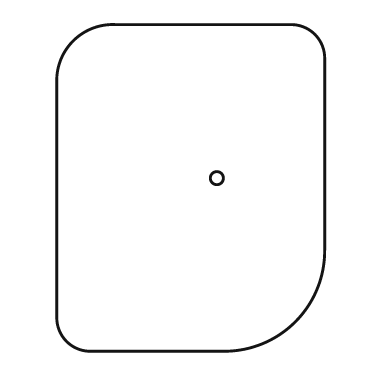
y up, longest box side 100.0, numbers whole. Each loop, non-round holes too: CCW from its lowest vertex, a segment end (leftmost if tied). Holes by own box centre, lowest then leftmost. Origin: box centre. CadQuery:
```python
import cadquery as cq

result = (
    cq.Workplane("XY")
    .moveTo(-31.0, -50.0)
    .lineTo(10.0, -50.0)
    .threePointArc((32.0, -41.0), (41.0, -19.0))
    .lineTo(41.0, 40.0)
    .threePointArc((38.0, 47.0), (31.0, 50.0))
    .lineTo(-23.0, 50.0)
    .threePointArc((-36.0, 45.0), (-41.0, 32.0))
    .lineTo(-41.0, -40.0)
    .threePointArc((-38.0, -47.0), (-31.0, -50.0))
    .close()
    .moveTo(8.0, 3.0)
    .circle(2.0)
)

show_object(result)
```